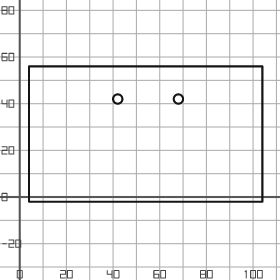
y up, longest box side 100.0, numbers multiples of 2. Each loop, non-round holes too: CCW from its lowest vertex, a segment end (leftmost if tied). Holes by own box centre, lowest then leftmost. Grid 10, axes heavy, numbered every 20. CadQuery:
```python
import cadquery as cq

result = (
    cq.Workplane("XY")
    .moveTo(4.0, -2.0)
    .lineTo(104.0, -2.0)
    .lineTo(104.0, 56.0)
    .lineTo(4.0, 56.0)
    .close()
    .moveTo(42.0, 42.0)
    .circle(2.0)
    .moveTo(68.0, 42.0)
    .circle(2.0)
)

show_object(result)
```